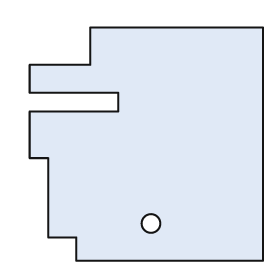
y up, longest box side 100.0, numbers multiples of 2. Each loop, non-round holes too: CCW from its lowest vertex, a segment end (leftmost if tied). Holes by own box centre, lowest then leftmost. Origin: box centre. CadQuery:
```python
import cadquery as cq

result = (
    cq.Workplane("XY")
    .moveTo(-30.0, -50.0)
    .lineTo(50.0, -50.0)
    .lineTo(50.0, 50.0)
    .lineTo(-24.0, 50.0)
    .lineTo(-24.0, 34.0)
    .lineTo(-50.0, 34.0)
    .lineTo(-50.0, 22.0)
    .lineTo(-12.0, 22.0)
    .lineTo(-12.0, 14.0)
    .lineTo(-50.0, 14.0)
    .lineTo(-50.0, -6.0)
    .lineTo(-42.0, -6.0)
    .lineTo(-42.0, -40.0)
    .lineTo(-30.0, -40.0)
    .close()
    .moveTo(2.0, -34.0)
    .circle(4.0)
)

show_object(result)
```